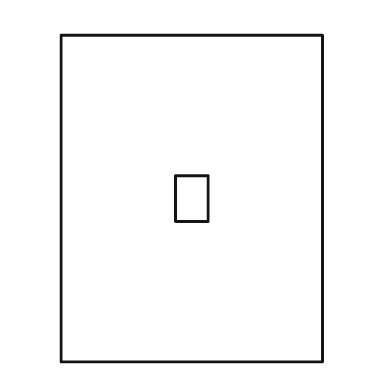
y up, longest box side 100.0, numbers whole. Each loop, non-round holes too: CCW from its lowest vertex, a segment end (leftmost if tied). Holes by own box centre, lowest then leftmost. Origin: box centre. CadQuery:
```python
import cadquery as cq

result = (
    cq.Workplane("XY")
    .moveTo(-40.0, -50.0)
    .lineTo(40.0, -50.0)
    .lineTo(40.0, 50.0)
    .lineTo(-40.0, 50.0)
    .close()
    .moveTo(-5.0, -7.0)
    .lineTo(5.0, -7.0)
    .lineTo(5.0, 7.0)
    .lineTo(-5.0, 7.0)
    .close()
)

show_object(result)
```